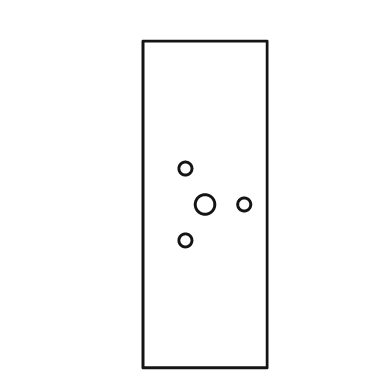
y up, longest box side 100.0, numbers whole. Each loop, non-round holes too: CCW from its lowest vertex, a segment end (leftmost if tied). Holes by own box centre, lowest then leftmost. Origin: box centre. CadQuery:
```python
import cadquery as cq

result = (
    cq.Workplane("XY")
    .moveTo(-19.0, -50.0)
    .lineTo(19.0, -50.0)
    .lineTo(19.0, 50.0)
    .lineTo(-19.0, 50.0)
    .close()
    .moveTo(-6.0, -11.0)
    .circle(2.0)
    .moveTo(0.0, 0.0)
    .circle(3.0)
    .moveTo(12.0, 0.0)
    .circle(2.0)
    .moveTo(-6.0, 11.0)
    .circle(2.0)
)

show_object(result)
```